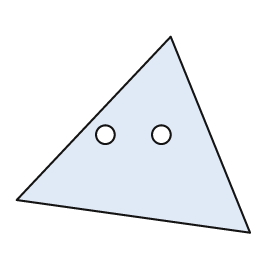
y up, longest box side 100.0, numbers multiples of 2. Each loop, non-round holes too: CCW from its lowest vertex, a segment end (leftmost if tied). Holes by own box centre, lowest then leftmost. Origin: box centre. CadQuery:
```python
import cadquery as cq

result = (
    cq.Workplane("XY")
    .moveTo(50.0, -42.0)
    .lineTo(16.0, 42.0)
    .lineTo(-50.0, -28.0)
    .close()
    .moveTo(-12.0, 0.0)
    .circle(4.0)
    .moveTo(12.0, 0.0)
    .circle(4.0)
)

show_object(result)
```